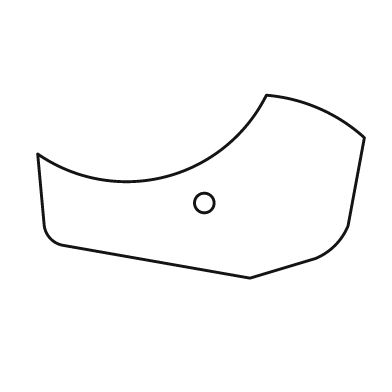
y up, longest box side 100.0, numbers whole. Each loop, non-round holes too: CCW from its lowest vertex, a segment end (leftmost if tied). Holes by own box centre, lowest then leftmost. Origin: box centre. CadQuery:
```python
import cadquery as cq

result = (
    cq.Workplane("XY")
    .moveTo(15.0, -28.0)
    .lineTo(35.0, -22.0)
    .threePointArc((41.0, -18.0), (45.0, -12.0))
    .lineTo(50.0, 15.0)
    .threePointArc((36.0, 24.0), (20.0, 28.0))
    .threePointArc((-11.0, 3.0), (-50.0, 10.0))
    .lineTo(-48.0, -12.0)
    .threePointArc((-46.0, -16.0), (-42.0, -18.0))
    .close()
    .moveTo(1.0, -5.0)
    .circle(3.0)
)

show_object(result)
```